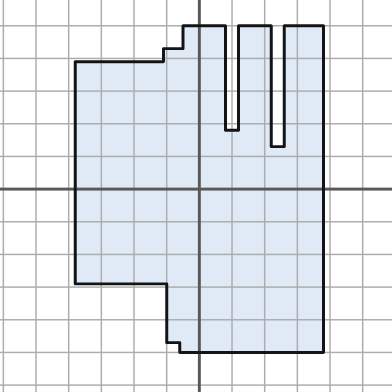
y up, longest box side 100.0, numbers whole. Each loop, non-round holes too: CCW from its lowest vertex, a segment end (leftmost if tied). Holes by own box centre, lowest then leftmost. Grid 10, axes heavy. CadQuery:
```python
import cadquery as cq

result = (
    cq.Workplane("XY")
    .moveTo(-6.0, -50.0)
    .lineTo(38.0, -50.0)
    .lineTo(38.0, 50.0)
    .lineTo(26.0, 50.0)
    .lineTo(26.0, 13.0)
    .lineTo(22.0, 13.0)
    .lineTo(22.0, 50.0)
    .lineTo(12.0, 50.0)
    .lineTo(12.0, 18.0)
    .lineTo(8.0, 18.0)
    .lineTo(8.0, 50.0)
    .lineTo(-5.0, 50.0)
    .lineTo(-5.0, 43.0)
    .lineTo(-11.0, 43.0)
    .lineTo(-11.0, 39.0)
    .lineTo(-38.0, 39.0)
    .lineTo(-38.0, -29.0)
    .lineTo(-10.0, -29.0)
    .lineTo(-10.0, -47.0)
    .lineTo(-6.0, -47.0)
    .close()
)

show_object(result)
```